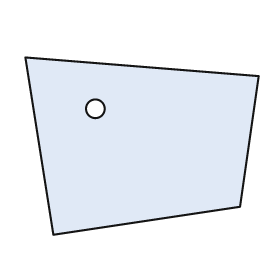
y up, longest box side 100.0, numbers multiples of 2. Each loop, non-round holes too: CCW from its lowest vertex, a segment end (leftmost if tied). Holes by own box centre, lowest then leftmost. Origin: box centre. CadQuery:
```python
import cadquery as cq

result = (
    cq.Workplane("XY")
    .moveTo(-38.0, -38.0)
    .lineTo(42.0, -26.0)
    .lineTo(50.0, 30.0)
    .lineTo(-50.0, 38.0)
    .close()
    .moveTo(-20.0, 16.0)
    .circle(4.0)
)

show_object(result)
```